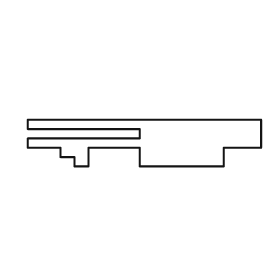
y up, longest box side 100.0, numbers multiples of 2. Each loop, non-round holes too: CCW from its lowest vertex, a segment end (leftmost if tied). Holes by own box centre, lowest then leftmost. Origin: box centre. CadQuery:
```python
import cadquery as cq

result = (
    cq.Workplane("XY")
    .moveTo(-30.0, -10.0)
    .lineTo(-24.0, -10.0)
    .lineTo(-24.0, -2.0)
    .lineTo(-2.0, -2.0)
    .lineTo(-2.0, -10.0)
    .lineTo(34.0, -10.0)
    .lineTo(34.0, -2.0)
    .lineTo(50.0, -2.0)
    .lineTo(50.0, 10.0)
    .lineTo(-50.0, 10.0)
    .lineTo(-50.0, 6.0)
    .lineTo(-2.0, 6.0)
    .lineTo(-2.0, 2.0)
    .lineTo(-50.0, 2.0)
    .lineTo(-50.0, -2.0)
    .lineTo(-36.0, -2.0)
    .lineTo(-36.0, -6.0)
    .lineTo(-30.0, -6.0)
    .close()
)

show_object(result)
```